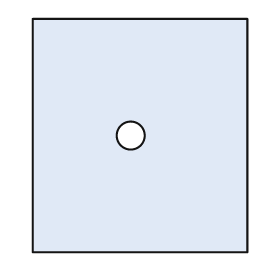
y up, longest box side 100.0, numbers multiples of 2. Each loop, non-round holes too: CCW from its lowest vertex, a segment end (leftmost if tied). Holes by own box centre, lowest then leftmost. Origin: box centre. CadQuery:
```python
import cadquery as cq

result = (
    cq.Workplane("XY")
    .moveTo(-46.0, -50.0)
    .lineTo(46.0, -50.0)
    .lineTo(46.0, 50.0)
    .lineTo(-46.0, 50.0)
    .close()
    .moveTo(-4.0, 0.0)
    .circle(6.0)
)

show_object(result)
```